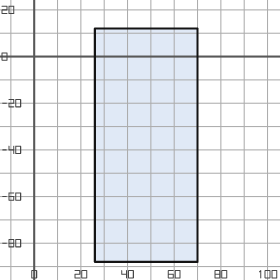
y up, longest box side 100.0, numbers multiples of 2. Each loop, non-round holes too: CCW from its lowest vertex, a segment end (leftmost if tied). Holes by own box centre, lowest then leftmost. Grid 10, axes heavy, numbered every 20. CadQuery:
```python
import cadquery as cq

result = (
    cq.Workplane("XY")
    .moveTo(26.0, -88.0)
    .lineTo(70.0, -88.0)
    .lineTo(70.0, 12.0)
    .lineTo(26.0, 12.0)
    .close()
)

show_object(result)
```